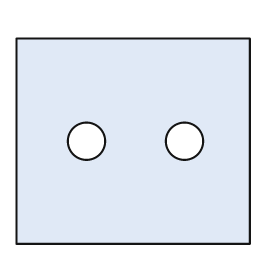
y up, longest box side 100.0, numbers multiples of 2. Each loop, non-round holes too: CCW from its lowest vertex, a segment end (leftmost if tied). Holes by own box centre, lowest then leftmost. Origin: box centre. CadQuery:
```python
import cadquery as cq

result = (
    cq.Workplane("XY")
    .moveTo(-50.0, -44.0)
    .lineTo(50.0, -44.0)
    .lineTo(50.0, 44.0)
    .lineTo(-50.0, 44.0)
    .close()
    .moveTo(-20.0, 0.0)
    .circle(8.0)
    .moveTo(22.0, 0.0)
    .circle(8.0)
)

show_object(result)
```